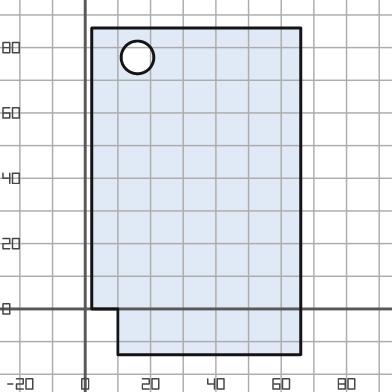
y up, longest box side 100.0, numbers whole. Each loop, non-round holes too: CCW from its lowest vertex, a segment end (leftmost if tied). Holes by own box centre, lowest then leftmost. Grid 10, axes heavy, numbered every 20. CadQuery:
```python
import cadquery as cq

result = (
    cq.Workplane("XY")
    .moveTo(10.0, -14.0)
    .lineTo(66.0, -14.0)
    .lineTo(66.0, 86.0)
    .lineTo(2.0, 86.0)
    .lineTo(2.0, 0.0)
    .lineTo(10.0, 0.0)
    .close()
    .moveTo(16.0, 77.0)
    .circle(5.0)
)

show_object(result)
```